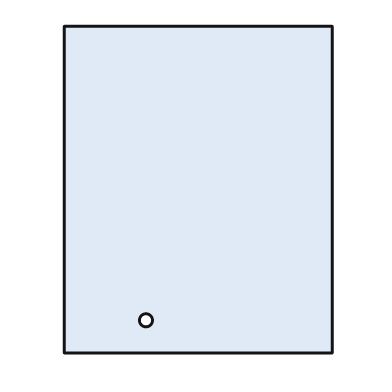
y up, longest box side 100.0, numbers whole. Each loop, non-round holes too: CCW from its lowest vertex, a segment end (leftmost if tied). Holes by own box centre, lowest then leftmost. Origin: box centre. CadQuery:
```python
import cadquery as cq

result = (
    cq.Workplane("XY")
    .moveTo(-41.0, -50.0)
    .lineTo(41.0, -50.0)
    .lineTo(41.0, 50.0)
    .lineTo(-41.0, 50.0)
    .close()
    .moveTo(-16.0, -40.0)
    .circle(2.0)
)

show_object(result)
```